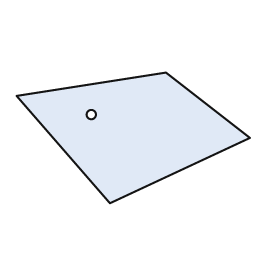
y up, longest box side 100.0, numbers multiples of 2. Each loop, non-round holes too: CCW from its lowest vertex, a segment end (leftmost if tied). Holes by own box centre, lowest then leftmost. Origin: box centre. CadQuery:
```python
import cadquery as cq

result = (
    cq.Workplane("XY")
    .moveTo(-10.0, -28.0)
    .lineTo(50.0, 0.0)
    .lineTo(14.0, 28.0)
    .lineTo(-50.0, 18.0)
    .close()
    .moveTo(-18.0, 10.0)
    .circle(2.0)
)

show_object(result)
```